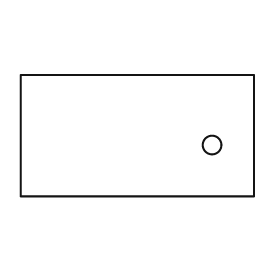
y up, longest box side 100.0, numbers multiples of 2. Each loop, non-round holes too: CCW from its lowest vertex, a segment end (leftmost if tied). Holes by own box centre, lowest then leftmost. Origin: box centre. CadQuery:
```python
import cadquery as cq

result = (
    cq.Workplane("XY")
    .moveTo(-50.0, -26.0)
    .lineTo(50.0, -26.0)
    .lineTo(50.0, 26.0)
    .lineTo(-50.0, 26.0)
    .close()
    .moveTo(32.0, -4.0)
    .circle(4.0)
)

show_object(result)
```